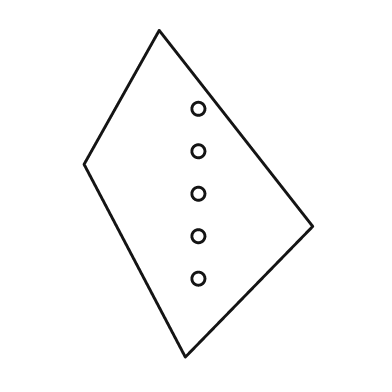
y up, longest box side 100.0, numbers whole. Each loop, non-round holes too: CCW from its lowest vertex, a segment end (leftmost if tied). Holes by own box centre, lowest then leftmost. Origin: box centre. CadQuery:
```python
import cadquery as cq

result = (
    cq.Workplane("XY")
    .moveTo(-4.0, -50.0)
    .lineTo(35.0, -10.0)
    .lineTo(-12.0, 50.0)
    .lineTo(-35.0, 9.0)
    .close()
    .moveTo(0.0, -26.0)
    .circle(2.0)
    .moveTo(0.0, -13.0)
    .circle(2.0)
    .moveTo(0.0, 0.0)
    .circle(2.0)
    .moveTo(0.0, 13.0)
    .circle(2.0)
    .moveTo(0.0, 26.0)
    .circle(2.0)
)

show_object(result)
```